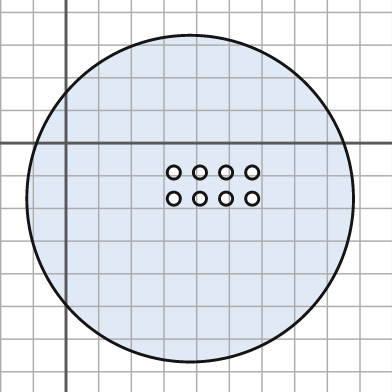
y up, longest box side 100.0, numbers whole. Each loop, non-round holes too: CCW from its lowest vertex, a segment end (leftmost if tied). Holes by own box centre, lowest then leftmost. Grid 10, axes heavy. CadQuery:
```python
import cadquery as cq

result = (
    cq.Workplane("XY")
    .moveTo(38.0, -17.0)
    .circle(50.0)
    .moveTo(33.0, -17.0)
    .circle(2.0)
    .moveTo(41.0, -17.0)
    .circle(2.0)
    .moveTo(49.0, -17.0)
    .circle(2.0)
    .moveTo(57.0, -17.0)
    .circle(2.0)
    .moveTo(33.0, -9.0)
    .circle(2.0)
    .moveTo(41.0, -9.0)
    .circle(2.0)
    .moveTo(49.0, -9.0)
    .circle(2.0)
    .moveTo(57.0, -9.0)
    .circle(2.0)
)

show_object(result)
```